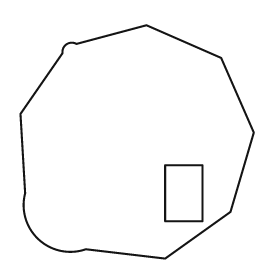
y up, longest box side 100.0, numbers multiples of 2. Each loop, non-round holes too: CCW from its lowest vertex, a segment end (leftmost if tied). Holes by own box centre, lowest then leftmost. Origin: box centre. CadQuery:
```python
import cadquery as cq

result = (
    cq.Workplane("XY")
    .moveTo(12.0, -50.0)
    .lineTo(40.0, -30.0)
    .lineTo(50.0, 4.0)
    .lineTo(36.0, 36.0)
    .lineTo(4.0, 50.0)
    .lineTo(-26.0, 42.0)
    .threePointArc((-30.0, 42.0), (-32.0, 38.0))
    .lineTo(-50.0, 12.0)
    .lineTo(-48.0, -22.0)
    .threePointArc((-42.0, -42.0), (-22.0, -46.0))
    .close()
    .moveTo(12.0, -34.0)
    .lineTo(28.0, -34.0)
    .lineTo(28.0, -10.0)
    .lineTo(12.0, -10.0)
    .close()
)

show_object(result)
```